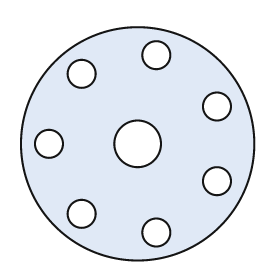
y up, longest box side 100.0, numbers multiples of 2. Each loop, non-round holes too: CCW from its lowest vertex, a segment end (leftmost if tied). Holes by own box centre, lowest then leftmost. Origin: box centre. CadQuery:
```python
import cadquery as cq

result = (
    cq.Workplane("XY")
    .moveTo(0.0, 0.0)
    .circle(50.0)
    .moveTo(8.0, -38.0)
    .circle(6.0)
    .moveTo(-24.0, -30.0)
    .circle(6.0)
    .moveTo(34.0, -16.0)
    .circle(6.0)
    .moveTo(-38.0, 0.0)
    .circle(6.0)
    .moveTo(0.0, 0.0)
    .circle(10.0)
    .moveTo(34.0, 16.0)
    .circle(6.0)
    .moveTo(-24.0, 30.0)
    .circle(6.0)
    .moveTo(8.0, 38.0)
    .circle(6.0)
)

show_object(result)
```